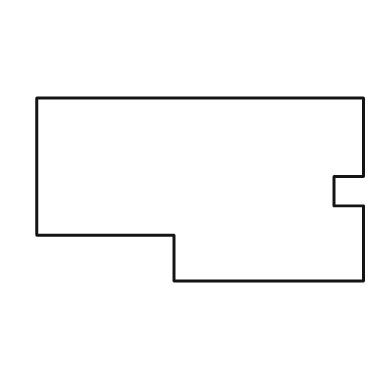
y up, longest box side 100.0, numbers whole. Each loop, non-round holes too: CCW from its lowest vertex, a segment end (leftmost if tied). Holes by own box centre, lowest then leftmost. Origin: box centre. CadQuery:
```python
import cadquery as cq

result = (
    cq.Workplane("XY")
    .moveTo(-8.0, -28.0)
    .lineTo(50.0, -28.0)
    .lineTo(50.0, -5.0)
    .lineTo(41.0, -5.0)
    .lineTo(41.0, 4.0)
    .lineTo(50.0, 4.0)
    .lineTo(50.0, 28.0)
    .lineTo(-50.0, 28.0)
    .lineTo(-50.0, -14.0)
    .lineTo(-8.0, -14.0)
    .close()
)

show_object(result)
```